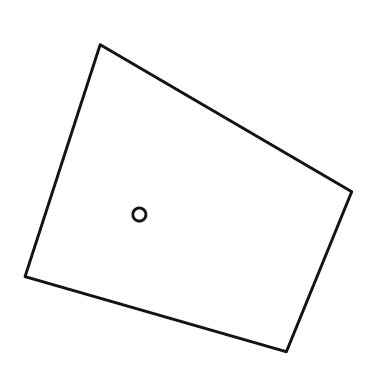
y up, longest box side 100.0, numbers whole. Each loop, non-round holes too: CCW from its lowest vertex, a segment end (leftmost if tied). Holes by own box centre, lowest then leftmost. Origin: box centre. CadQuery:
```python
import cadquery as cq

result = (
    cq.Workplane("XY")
    .moveTo(30.0, -47.0)
    .lineTo(50.0, 2.0)
    .lineTo(-27.0, 47.0)
    .lineTo(-50.0, -24.0)
    .close()
    .moveTo(-15.0, -5.0)
    .circle(2.0)
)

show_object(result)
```